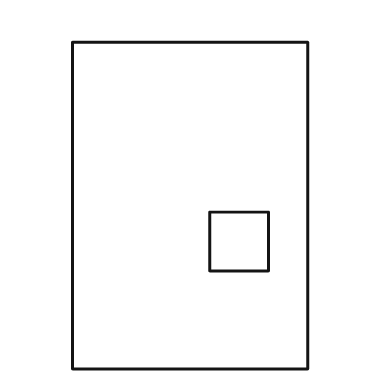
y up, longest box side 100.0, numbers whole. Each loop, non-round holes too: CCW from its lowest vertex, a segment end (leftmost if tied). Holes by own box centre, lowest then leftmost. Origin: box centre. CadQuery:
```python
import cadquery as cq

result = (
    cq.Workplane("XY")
    .moveTo(-36.0, -50.0)
    .lineTo(36.0, -50.0)
    .lineTo(36.0, 50.0)
    .lineTo(-36.0, 50.0)
    .close()
    .moveTo(6.0, -20.0)
    .lineTo(24.0, -20.0)
    .lineTo(24.0, -2.0)
    .lineTo(6.0, -2.0)
    .close()
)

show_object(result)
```